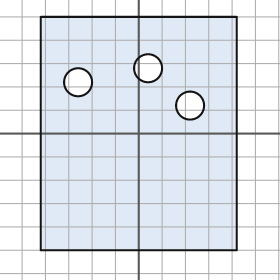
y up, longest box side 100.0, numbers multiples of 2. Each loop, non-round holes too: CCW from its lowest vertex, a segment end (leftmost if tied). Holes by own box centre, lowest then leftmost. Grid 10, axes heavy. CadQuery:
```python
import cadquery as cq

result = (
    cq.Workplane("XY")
    .moveTo(-42.0, -50.0)
    .lineTo(42.0, -50.0)
    .lineTo(42.0, 50.0)
    .lineTo(-42.0, 50.0)
    .close()
    .moveTo(22.0, 12.0)
    .circle(6.0)
    .moveTo(-26.0, 22.0)
    .circle(6.0)
    .moveTo(4.0, 28.0)
    .circle(6.0)
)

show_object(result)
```